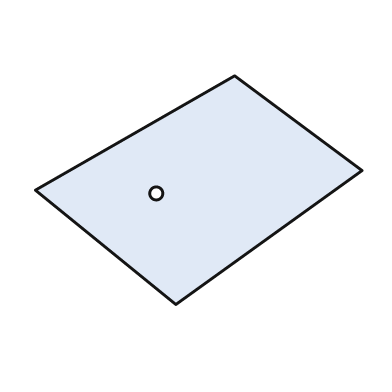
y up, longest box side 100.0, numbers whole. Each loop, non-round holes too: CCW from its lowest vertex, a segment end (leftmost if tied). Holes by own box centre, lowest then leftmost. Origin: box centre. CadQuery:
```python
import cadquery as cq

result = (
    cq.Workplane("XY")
    .moveTo(-7.0, -35.0)
    .lineTo(50.0, 6.0)
    .lineTo(11.0, 35.0)
    .lineTo(-50.0, 0.0)
    .close()
    .moveTo(-13.0, -1.0)
    .circle(2.0)
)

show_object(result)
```